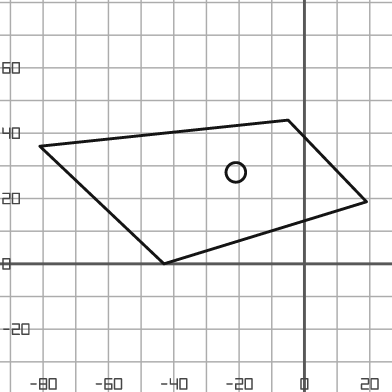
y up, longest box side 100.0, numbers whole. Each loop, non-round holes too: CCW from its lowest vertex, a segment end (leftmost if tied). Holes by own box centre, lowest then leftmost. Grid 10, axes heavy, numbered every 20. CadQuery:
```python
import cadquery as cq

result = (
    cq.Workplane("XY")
    .moveTo(-43.0, 0.0)
    .lineTo(19.0, 19.0)
    .lineTo(-5.0, 44.0)
    .lineTo(-81.0, 36.0)
    .close()
    .moveTo(-21.0, 28.0)
    .circle(3.0)
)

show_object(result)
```